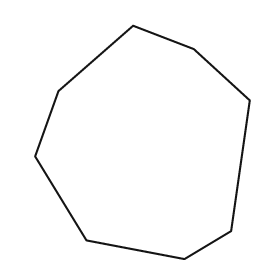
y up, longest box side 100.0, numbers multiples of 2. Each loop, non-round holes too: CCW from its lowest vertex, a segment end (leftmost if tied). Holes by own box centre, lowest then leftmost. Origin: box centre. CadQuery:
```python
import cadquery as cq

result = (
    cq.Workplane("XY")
    .moveTo(18.0, -50.0)
    .lineTo(38.0, -38.0)
    .lineTo(46.0, 18.0)
    .lineTo(22.0, 40.0)
    .lineTo(-4.0, 50.0)
    .lineTo(-36.0, 22.0)
    .lineTo(-46.0, -6.0)
    .lineTo(-24.0, -42.0)
    .close()
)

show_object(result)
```